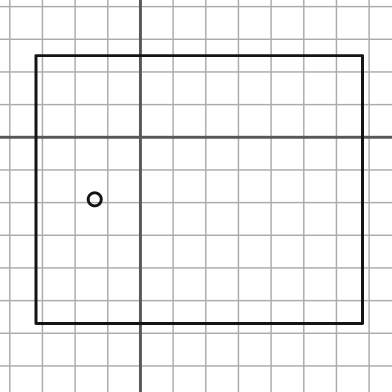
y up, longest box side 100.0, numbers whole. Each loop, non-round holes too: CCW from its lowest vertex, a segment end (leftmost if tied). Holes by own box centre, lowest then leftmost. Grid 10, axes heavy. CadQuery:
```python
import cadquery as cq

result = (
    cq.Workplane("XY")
    .moveTo(-32.0, -57.0)
    .lineTo(68.0, -57.0)
    .lineTo(68.0, 25.0)
    .lineTo(-32.0, 25.0)
    .close()
    .moveTo(-14.0, -19.0)
    .circle(2.0)
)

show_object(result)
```